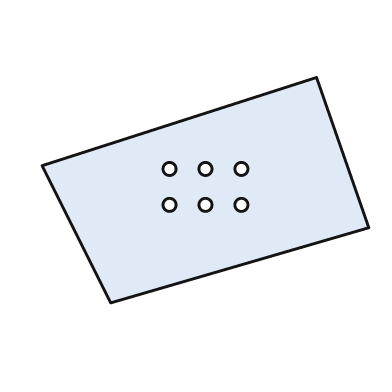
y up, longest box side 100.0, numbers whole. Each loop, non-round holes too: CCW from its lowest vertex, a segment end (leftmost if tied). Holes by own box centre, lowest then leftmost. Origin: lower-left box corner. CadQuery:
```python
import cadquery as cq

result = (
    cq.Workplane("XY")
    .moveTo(21.0, 0.0)
    .lineTo(100.0, 23.0)
    .lineTo(84.0, 69.0)
    .lineTo(0.0, 42.0)
    .close()
    .moveTo(39.0, 30.0)
    .circle(2.0)
    .moveTo(50.0, 30.0)
    .circle(2.0)
    .moveTo(61.0, 30.0)
    .circle(2.0)
    .moveTo(39.0, 41.0)
    .circle(2.0)
    .moveTo(50.0, 41.0)
    .circle(2.0)
    .moveTo(61.0, 41.0)
    .circle(2.0)
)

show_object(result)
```